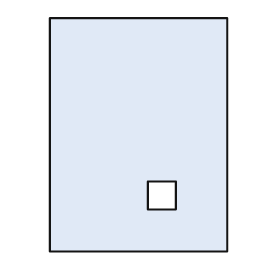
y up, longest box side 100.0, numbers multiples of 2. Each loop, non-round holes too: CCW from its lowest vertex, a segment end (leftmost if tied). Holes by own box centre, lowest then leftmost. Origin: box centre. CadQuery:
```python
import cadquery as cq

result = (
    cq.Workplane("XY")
    .moveTo(-38.0, -50.0)
    .lineTo(38.0, -50.0)
    .lineTo(38.0, 50.0)
    .lineTo(-38.0, 50.0)
    .close()
    .moveTo(4.0, -32.0)
    .lineTo(16.0, -32.0)
    .lineTo(16.0, -20.0)
    .lineTo(4.0, -20.0)
    .close()
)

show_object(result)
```